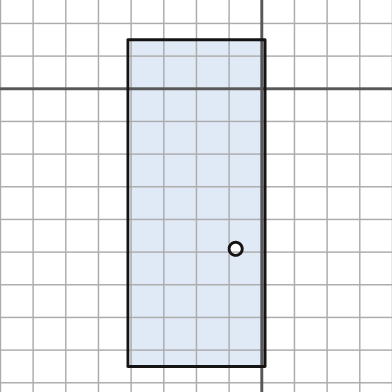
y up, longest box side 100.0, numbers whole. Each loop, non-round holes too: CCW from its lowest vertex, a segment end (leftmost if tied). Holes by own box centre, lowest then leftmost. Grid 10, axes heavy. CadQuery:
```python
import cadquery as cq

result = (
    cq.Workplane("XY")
    .moveTo(-41.0, -85.0)
    .lineTo(1.0, -85.0)
    .lineTo(1.0, 15.0)
    .lineTo(-41.0, 15.0)
    .close()
    .moveTo(-8.0, -49.0)
    .circle(2.0)
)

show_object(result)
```